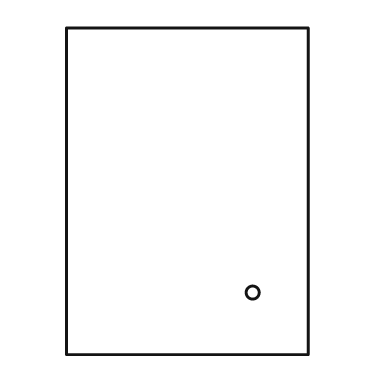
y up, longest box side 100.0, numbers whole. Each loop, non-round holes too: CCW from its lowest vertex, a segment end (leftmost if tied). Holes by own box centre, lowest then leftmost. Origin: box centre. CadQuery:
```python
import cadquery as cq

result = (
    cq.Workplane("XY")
    .moveTo(-37.0, -50.0)
    .lineTo(37.0, -50.0)
    .lineTo(37.0, 50.0)
    .lineTo(-37.0, 50.0)
    .close()
    .moveTo(20.0, -31.0)
    .circle(2.0)
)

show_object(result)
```